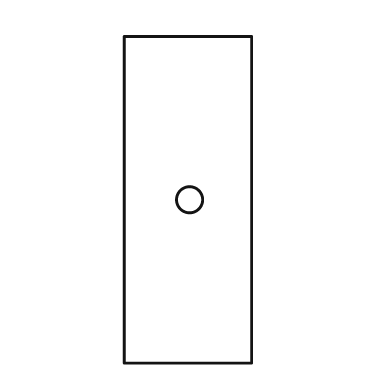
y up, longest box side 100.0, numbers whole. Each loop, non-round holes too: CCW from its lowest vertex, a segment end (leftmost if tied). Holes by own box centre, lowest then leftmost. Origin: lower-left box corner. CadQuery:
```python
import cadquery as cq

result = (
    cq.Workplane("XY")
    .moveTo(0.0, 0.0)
    .lineTo(39.0, 0.0)
    .lineTo(39.0, 100.0)
    .lineTo(0.0, 100.0)
    .close()
    .moveTo(20.0, 50.0)
    .circle(4.0)
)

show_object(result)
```